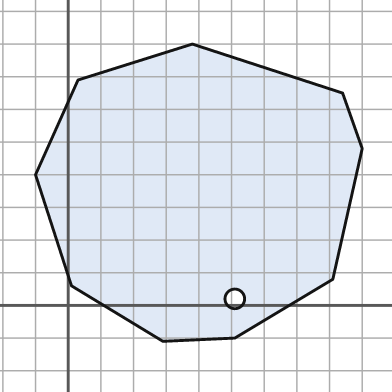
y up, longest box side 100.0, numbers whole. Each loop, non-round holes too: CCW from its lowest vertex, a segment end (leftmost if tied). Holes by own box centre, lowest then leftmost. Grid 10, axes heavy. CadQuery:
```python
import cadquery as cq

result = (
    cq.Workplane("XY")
    .moveTo(29.0, -11.0)
    .lineTo(51.0, -10.0)
    .lineTo(81.0, 8.0)
    .lineTo(90.0, 48.0)
    .lineTo(84.0, 65.0)
    .lineTo(38.0, 80.0)
    .lineTo(3.0, 69.0)
    .lineTo(-10.0, 40.0)
    .lineTo(1.0, 6.0)
    .close()
    .moveTo(51.0, 2.0)
    .circle(3.0)
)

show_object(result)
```